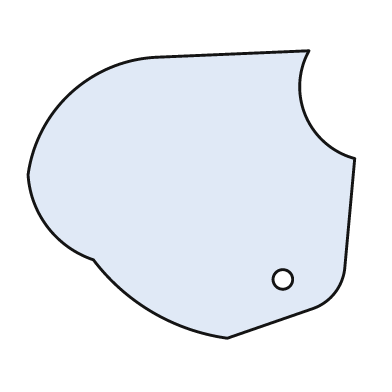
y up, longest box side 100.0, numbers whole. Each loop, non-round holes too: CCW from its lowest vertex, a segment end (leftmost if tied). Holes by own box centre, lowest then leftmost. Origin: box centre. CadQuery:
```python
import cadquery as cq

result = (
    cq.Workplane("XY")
    .moveTo(11.0, -44.0)
    .lineTo(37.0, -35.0)
    .threePointArc((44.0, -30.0), (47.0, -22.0))
    .lineTo(50.0, 11.0)
    .threePointArc((35.0, 24.0), (36.0, 44.0))
    .lineTo(-11.0, 42.0)
    .threePointArc((-37.0, 31.0), (-50.0, 6.0))
    .threePointArc((-44.0, -10.0), (-30.0, -20.0))
    .threePointArc((-12.0, -36.0), (11.0, -44.0))
    .close()
    .moveTo(28.0, -26.0)
    .circle(3.0)
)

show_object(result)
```